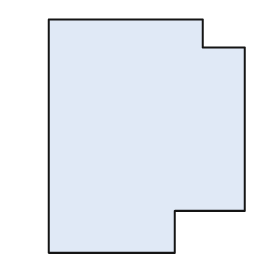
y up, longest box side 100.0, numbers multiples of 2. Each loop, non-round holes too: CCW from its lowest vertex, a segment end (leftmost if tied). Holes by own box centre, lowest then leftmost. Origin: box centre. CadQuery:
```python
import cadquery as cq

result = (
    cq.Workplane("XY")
    .moveTo(-42.0, -50.0)
    .lineTo(12.0, -50.0)
    .lineTo(12.0, -32.0)
    .lineTo(42.0, -32.0)
    .lineTo(42.0, 38.0)
    .lineTo(24.0, 38.0)
    .lineTo(24.0, 50.0)
    .lineTo(-42.0, 50.0)
    .close()
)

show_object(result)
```